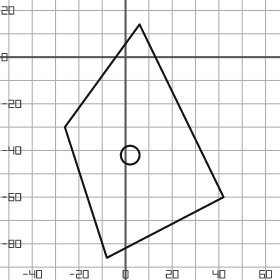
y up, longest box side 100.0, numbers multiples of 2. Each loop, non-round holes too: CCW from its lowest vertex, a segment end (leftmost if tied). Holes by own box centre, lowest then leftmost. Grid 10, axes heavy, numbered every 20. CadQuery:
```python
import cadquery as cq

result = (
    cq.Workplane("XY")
    .moveTo(-8.0, -86.0)
    .lineTo(42.0, -60.0)
    .lineTo(6.0, 14.0)
    .lineTo(-26.0, -30.0)
    .close()
    .moveTo(2.0, -42.0)
    .circle(4.0)
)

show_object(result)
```